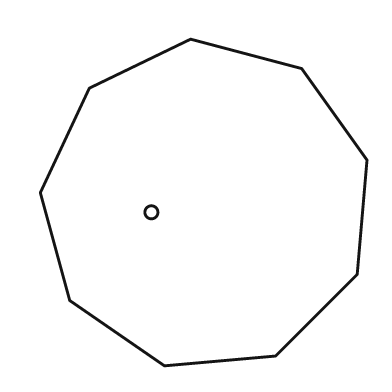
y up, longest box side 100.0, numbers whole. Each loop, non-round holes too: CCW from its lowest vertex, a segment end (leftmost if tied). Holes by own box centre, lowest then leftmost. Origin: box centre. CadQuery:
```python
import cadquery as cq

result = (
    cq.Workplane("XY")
    .moveTo(-12.0, -50.0)
    .lineTo(22.0, -47.0)
    .lineTo(47.0, -22.0)
    .lineTo(50.0, 13.0)
    .lineTo(30.0, 41.0)
    .lineTo(-4.0, 50.0)
    .lineTo(-35.0, 35.0)
    .lineTo(-50.0, 3.0)
    .lineTo(-41.0, -30.0)
    .close()
    .moveTo(-16.0, -3.0)
    .circle(2.0)
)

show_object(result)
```